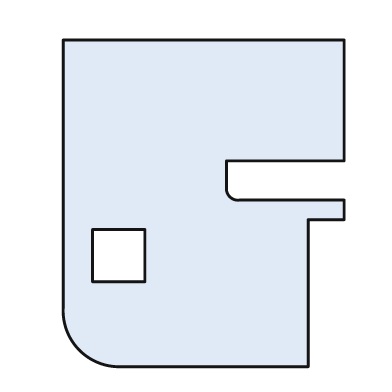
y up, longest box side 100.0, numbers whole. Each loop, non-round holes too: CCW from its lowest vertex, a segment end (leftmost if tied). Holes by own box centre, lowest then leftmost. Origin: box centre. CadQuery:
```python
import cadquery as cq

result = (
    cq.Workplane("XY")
    .moveTo(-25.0, -50.0)
    .lineTo(32.0, -50.0)
    .lineTo(32.0, -5.0)
    .lineTo(43.0, -5.0)
    .lineTo(43.0, 1.0)
    .lineTo(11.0, 1.0)
    .threePointArc((8.0, 2.0), (7.0, 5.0))
    .lineTo(7.0, 13.0)
    .lineTo(43.0, 13.0)
    .lineTo(43.0, 50.0)
    .lineTo(-43.0, 50.0)
    .lineTo(-43.0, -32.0)
    .threePointArc((-38.0, -45.0), (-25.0, -50.0))
    .close()
    .moveTo(-34.0, -24.0)
    .lineTo(-18.0, -24.0)
    .lineTo(-18.0, -8.0)
    .lineTo(-34.0, -8.0)
    .close()
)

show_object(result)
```